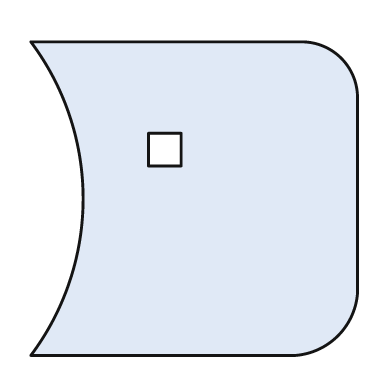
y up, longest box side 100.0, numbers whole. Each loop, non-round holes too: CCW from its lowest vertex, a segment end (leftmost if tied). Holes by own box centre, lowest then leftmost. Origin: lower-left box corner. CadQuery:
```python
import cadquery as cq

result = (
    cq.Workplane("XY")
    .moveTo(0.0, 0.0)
    .lineTo(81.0, 0.0)
    .threePointArc((94.0, 6.0), (100.0, 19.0))
    .lineTo(100.0, 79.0)
    .threePointArc((95.0, 91.0), (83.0, 96.0))
    .lineTo(0.0, 96.0)
    .threePointArc((16.0, 48.0), (0.0, 0.0))
    .close()
    .moveTo(36.0, 58.0)
    .lineTo(46.0, 58.0)
    .lineTo(46.0, 68.0)
    .lineTo(36.0, 68.0)
    .close()
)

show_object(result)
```